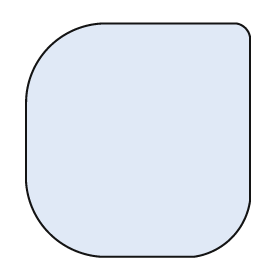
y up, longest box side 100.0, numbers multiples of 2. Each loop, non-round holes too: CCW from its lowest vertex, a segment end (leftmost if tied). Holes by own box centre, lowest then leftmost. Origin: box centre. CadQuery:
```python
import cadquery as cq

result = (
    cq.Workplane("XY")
    .moveTo(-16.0, -50.0)
    .lineTo(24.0, -50.0)
    .threePointArc((40.0, -42.0), (48.0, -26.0))
    .lineTo(48.0, 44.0)
    .threePointArc((46.0, 48.0), (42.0, 50.0))
    .lineTo(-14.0, 50.0)
    .threePointArc((-38.0, 40.0), (-48.0, 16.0))
    .lineTo(-48.0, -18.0)
    .threePointArc((-38.0, -40.0), (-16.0, -50.0))
    .close()
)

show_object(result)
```